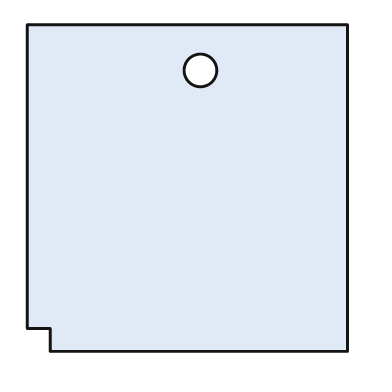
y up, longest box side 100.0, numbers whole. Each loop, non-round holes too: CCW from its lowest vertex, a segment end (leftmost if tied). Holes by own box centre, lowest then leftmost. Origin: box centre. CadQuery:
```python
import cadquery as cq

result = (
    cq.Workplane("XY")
    .moveTo(-42.0, -50.0)
    .lineTo(49.0, -50.0)
    .lineTo(49.0, 50.0)
    .lineTo(-49.0, 50.0)
    .lineTo(-49.0, -43.0)
    .lineTo(-42.0, -43.0)
    .close()
    .moveTo(4.0, 36.0)
    .circle(5.0)
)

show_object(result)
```